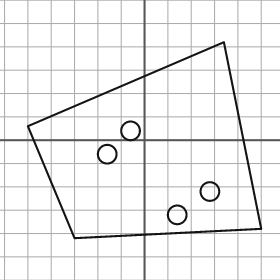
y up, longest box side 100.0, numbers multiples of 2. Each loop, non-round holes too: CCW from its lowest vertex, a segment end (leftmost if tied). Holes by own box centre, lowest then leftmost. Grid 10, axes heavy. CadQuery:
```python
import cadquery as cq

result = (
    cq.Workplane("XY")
    .moveTo(-30.0, -42.0)
    .lineTo(50.0, -38.0)
    .lineTo(34.0, 42.0)
    .lineTo(-50.0, 6.0)
    .close()
    .moveTo(14.0, -32.0)
    .circle(4.0)
    .moveTo(28.0, -22.0)
    .circle(4.0)
    .moveTo(-16.0, -6.0)
    .circle(4.0)
    .moveTo(-6.0, 4.0)
    .circle(4.0)
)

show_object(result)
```